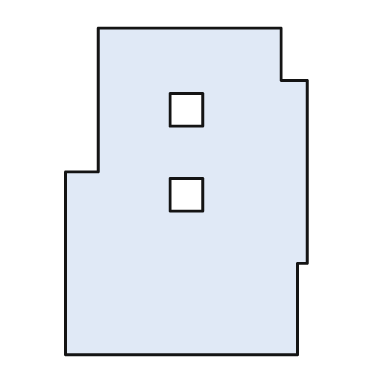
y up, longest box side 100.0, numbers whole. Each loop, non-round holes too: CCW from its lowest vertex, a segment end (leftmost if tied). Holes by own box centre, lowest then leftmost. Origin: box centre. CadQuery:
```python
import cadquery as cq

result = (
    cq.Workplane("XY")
    .moveTo(-37.0, -50.0)
    .lineTo(34.0, -50.0)
    .lineTo(34.0, -22.0)
    .lineTo(37.0, -22.0)
    .lineTo(37.0, 34.0)
    .lineTo(29.0, 34.0)
    .lineTo(29.0, 50.0)
    .lineTo(-27.0, 50.0)
    .lineTo(-27.0, 6.0)
    .lineTo(-37.0, 6.0)
    .close()
    .moveTo(-5.0, -6.0)
    .lineTo(5.0, -6.0)
    .lineTo(5.0, 4.0)
    .lineTo(-5.0, 4.0)
    .close()
    .moveTo(-5.0, 20.0)
    .lineTo(5.0, 20.0)
    .lineTo(5.0, 30.0)
    .lineTo(-5.0, 30.0)
    .close()
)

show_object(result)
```